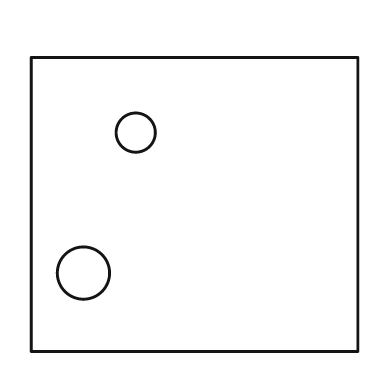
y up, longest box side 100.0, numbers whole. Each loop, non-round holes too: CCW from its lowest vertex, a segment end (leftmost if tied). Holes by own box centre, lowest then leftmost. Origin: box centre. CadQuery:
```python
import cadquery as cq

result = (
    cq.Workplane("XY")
    .moveTo(-50.0, -45.0)
    .lineTo(50.0, -45.0)
    .lineTo(50.0, 45.0)
    .lineTo(-50.0, 45.0)
    .close()
    .moveTo(-34.0, -21.0)
    .circle(8.0)
    .moveTo(-18.0, 22.0)
    .circle(6.0)
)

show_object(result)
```